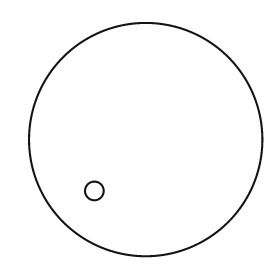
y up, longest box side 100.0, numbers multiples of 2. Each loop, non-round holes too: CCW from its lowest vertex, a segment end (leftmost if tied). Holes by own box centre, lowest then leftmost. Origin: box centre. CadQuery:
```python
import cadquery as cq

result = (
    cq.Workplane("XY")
    .moveTo(0.0, 0.0)
    .circle(50.0)
    .moveTo(-22.0, -22.0)
    .circle(4.0)
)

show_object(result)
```